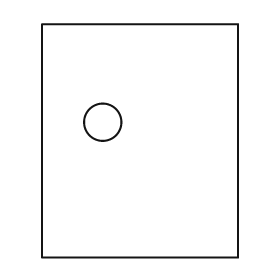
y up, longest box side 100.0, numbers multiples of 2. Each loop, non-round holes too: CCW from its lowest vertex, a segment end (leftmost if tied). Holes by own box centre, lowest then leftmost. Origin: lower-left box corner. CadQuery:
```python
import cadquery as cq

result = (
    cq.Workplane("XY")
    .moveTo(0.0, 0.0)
    .lineTo(84.0, 0.0)
    .lineTo(84.0, 100.0)
    .lineTo(0.0, 100.0)
    .close()
    .moveTo(26.0, 58.0)
    .circle(8.0)
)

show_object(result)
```